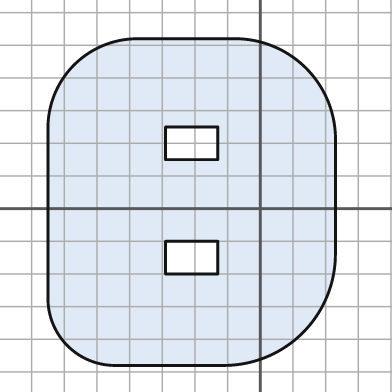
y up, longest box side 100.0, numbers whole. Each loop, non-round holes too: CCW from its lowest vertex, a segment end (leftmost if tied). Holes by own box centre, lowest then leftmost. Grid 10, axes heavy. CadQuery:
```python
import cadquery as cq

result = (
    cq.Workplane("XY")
    .moveTo(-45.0, -48.0)
    .lineTo(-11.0, -48.0)
    .threePointArc((13.0, -38.0), (23.0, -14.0))
    .lineTo(23.0, 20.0)
    .threePointArc((14.0, 43.0), (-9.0, 52.0))
    .lineTo(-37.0, 52.0)
    .threePointArc((-57.0, 44.0), (-65.0, 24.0))
    .lineTo(-65.0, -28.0)
    .threePointArc((-59.0, -42.0), (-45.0, -48.0))
    .close()
    .moveTo(-29.0, -20.0)
    .lineTo(-13.0, -20.0)
    .lineTo(-13.0, -10.0)
    .lineTo(-29.0, -10.0)
    .close()
    .moveTo(-29.0, 15.0)
    .lineTo(-13.0, 15.0)
    .lineTo(-13.0, 25.0)
    .lineTo(-29.0, 25.0)
    .close()
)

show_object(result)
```